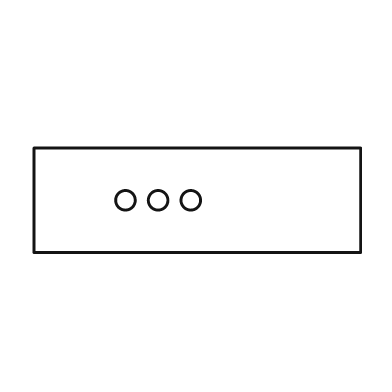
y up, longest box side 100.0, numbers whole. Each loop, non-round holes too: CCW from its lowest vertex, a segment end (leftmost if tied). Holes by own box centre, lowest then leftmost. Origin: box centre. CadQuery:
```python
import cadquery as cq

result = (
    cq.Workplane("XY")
    .moveTo(-50.0, -16.0)
    .lineTo(50.0, -16.0)
    .lineTo(50.0, 16.0)
    .lineTo(-50.0, 16.0)
    .close()
    .moveTo(-22.0, 0.0)
    .circle(3.0)
    .moveTo(-12.0, 0.0)
    .circle(3.0)
    .moveTo(-2.0, 0.0)
    .circle(3.0)
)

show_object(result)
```